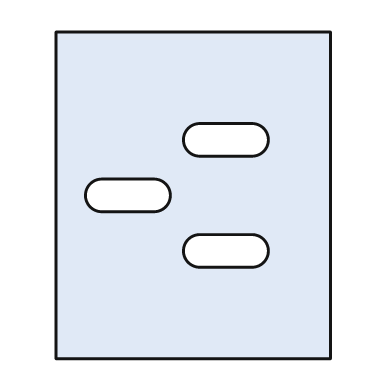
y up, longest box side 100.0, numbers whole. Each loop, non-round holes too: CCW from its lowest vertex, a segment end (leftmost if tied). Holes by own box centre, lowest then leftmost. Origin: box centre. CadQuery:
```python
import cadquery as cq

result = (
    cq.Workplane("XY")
    .moveTo(-42.0, -50.0)
    .lineTo(42.0, -50.0)
    .lineTo(42.0, 50.0)
    .lineTo(-42.0, 50.0)
    .close()
    .moveTo(2.0, -22.0)
    .lineTo(18.0, -22.0)
    .threePointArc((23.0, -17.0), (18.0, -12.0))
    .lineTo(2.0, -12.0)
    .threePointArc((-3.0, -17.0), (2.0, -22.0))
    .close()
    .moveTo(-28.0, -5.0)
    .lineTo(-12.0, -5.0)
    .threePointArc((-7.0, 0.0), (-12.0, 5.0))
    .lineTo(-28.0, 5.0)
    .threePointArc((-33.0, 0.0), (-28.0, -5.0))
    .close()
    .moveTo(2.0, 12.0)
    .lineTo(18.0, 12.0)
    .threePointArc((23.0, 17.0), (18.0, 22.0))
    .lineTo(2.0, 22.0)
    .threePointArc((-3.0, 17.0), (2.0, 12.0))
    .close()
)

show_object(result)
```